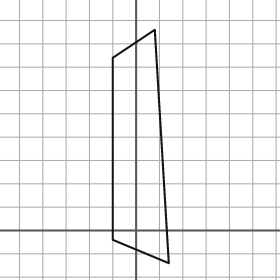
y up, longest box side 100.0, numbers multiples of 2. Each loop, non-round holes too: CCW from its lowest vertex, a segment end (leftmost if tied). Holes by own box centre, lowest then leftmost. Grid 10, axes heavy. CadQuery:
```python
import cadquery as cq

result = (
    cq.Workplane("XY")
    .moveTo(14.0, -14.0)
    .lineTo(8.0, 86.0)
    .lineTo(-10.0, 74.0)
    .lineTo(-10.0, -4.0)
    .close()
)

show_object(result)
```